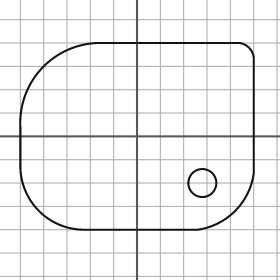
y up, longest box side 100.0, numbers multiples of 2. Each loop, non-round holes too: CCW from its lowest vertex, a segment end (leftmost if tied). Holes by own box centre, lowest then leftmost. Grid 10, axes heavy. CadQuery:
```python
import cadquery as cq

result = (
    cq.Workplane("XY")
    .moveTo(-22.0, -40.0)
    .lineTo(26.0, -40.0)
    .threePointArc((42.0, -32.0), (50.0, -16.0))
    .lineTo(50.0, 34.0)
    .threePointArc((48.0, 38.0), (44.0, 40.0))
    .lineTo(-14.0, 40.0)
    .threePointArc((-40.0, 30.0), (-50.0, 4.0))
    .lineTo(-50.0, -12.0)
    .threePointArc((-42.0, -32.0), (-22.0, -40.0))
    .close()
    .moveTo(28.0, -20.0)
    .circle(6.0)
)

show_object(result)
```